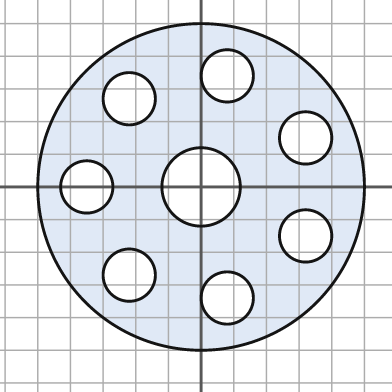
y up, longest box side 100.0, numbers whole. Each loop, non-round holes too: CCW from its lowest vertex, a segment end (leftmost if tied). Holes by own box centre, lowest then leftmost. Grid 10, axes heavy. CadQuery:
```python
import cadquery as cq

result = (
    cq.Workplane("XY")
    .moveTo(0.0, 0.0)
    .circle(50.0)
    .moveTo(8.0, -34.0)
    .circle(8.0)
    .moveTo(-22.0, -27.0)
    .circle(8.0)
    .moveTo(32.0, -15.0)
    .circle(8.0)
    .moveTo(-35.0, 0.0)
    .circle(8.0)
    .moveTo(0.0, 0.0)
    .circle(12.0)
    .moveTo(32.0, 15.0)
    .circle(8.0)
    .moveTo(-22.0, 27.0)
    .circle(8.0)
    .moveTo(8.0, 34.0)
    .circle(8.0)
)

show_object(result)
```